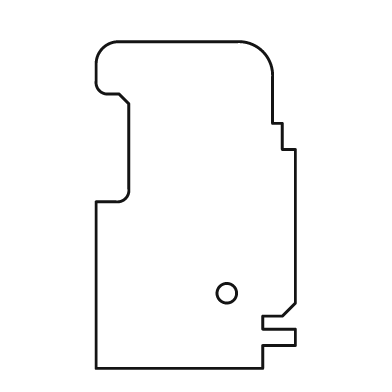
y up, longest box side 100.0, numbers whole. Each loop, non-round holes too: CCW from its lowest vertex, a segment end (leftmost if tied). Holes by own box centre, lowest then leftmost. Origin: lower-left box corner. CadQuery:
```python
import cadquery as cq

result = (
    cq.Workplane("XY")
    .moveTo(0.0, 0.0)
    .lineTo(51.0, 0.0)
    .lineTo(51.0, 7.0)
    .lineTo(61.0, 7.0)
    .lineTo(61.0, 12.0)
    .lineTo(51.0, 12.0)
    .lineTo(51.0, 16.0)
    .lineTo(57.0, 16.0)
    .lineTo(61.0, 20.0)
    .lineTo(61.0, 67.0)
    .lineTo(57.0, 67.0)
    .lineTo(57.0, 75.0)
    .lineTo(54.0, 75.0)
    .lineTo(54.0, 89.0)
    .threePointArc((51.0, 97.0), (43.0, 100.0))
    .lineTo(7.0, 100.0)
    .threePointArc((2.0, 98.0), (0.0, 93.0))
    .lineTo(0.0, 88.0)
    .threePointArc((1.0, 85.0), (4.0, 84.0))
    .lineTo(7.0, 84.0)
    .lineTo(10.0, 81.0)
    .lineTo(10.0, 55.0)
    .threePointArc((9.0, 52.0), (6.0, 51.0))
    .lineTo(0.0, 51.0)
    .close()
    .moveTo(40.0, 23.0)
    .circle(3.0)
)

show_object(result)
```